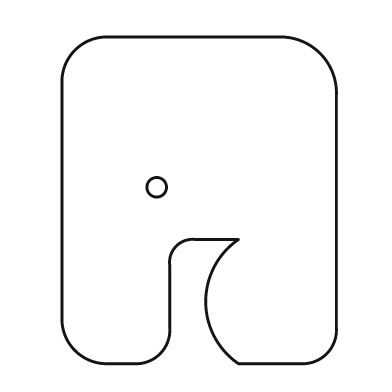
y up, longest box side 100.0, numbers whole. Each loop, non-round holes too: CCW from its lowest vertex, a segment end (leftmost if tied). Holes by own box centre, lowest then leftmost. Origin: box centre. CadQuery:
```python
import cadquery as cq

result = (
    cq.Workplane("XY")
    .moveTo(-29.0, -50.0)
    .lineTo(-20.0, -50.0)
    .threePointArc((-12.0, -47.0), (-9.0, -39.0))
    .lineTo(-9.0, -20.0)
    .threePointArc((-7.0, -14.0), (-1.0, -12.0))
    .lineTo(12.0, -12.0)
    .threePointArc((2.0, -31.0), (12.0, -50.0))
    .lineTo(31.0, -50.0)
    .threePointArc((39.0, -47.0), (42.0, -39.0))
    .lineTo(42.0, 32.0)
    .threePointArc((37.0, 45.0), (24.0, 50.0))
    .lineTo(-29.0, 50.0)
    .threePointArc((-38.0, 46.0), (-42.0, 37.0))
    .lineTo(-42.0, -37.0)
    .threePointArc((-38.0, -46.0), (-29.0, -50.0))
    .close()
    .moveTo(-13.0, 4.0)
    .circle(3.0)
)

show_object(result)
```